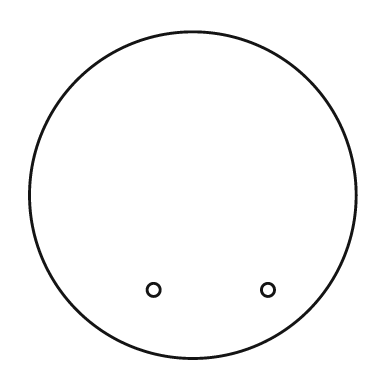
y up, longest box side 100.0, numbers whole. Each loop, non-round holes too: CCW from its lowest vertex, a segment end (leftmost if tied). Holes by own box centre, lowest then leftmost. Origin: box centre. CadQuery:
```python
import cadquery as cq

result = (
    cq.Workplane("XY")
    .moveTo(0.0, 0.0)
    .circle(50.0)
    .moveTo(-12.0, -29.0)
    .circle(2.0)
    .moveTo(23.0, -29.0)
    .circle(2.0)
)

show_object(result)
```